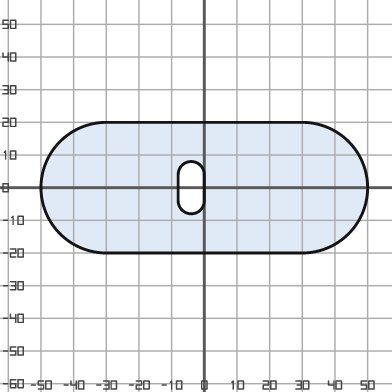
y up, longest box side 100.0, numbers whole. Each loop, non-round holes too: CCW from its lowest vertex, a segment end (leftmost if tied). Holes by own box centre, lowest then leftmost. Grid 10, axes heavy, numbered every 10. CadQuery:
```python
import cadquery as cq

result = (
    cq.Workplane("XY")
    .moveTo(-30.0, -20.0)
    .lineTo(30.0, -20.0)
    .threePointArc((50.0, 0.0), (30.0, 20.0))
    .lineTo(-30.0, 20.0)
    .threePointArc((-50.0, 0.0), (-30.0, -20.0))
    .close()
    .moveTo(-8.0, -4.0)
    .threePointArc((-4.0, -8.0), (0.0, -4.0))
    .lineTo(0.0, 4.0)
    .threePointArc((-4.0, 8.0), (-8.0, 4.0))
    .close()
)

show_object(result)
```